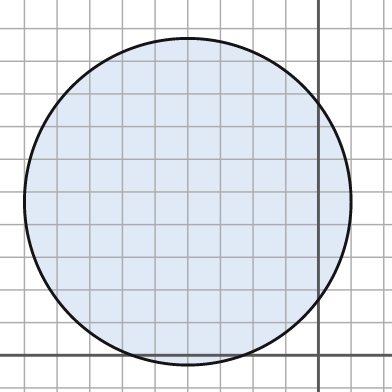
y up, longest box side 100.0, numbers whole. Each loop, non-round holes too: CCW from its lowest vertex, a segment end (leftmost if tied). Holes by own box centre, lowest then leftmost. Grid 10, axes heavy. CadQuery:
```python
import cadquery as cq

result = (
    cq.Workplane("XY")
    .moveTo(-40.0, 47.0)
    .circle(50.0)
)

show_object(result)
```